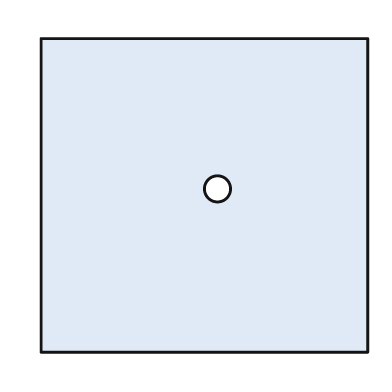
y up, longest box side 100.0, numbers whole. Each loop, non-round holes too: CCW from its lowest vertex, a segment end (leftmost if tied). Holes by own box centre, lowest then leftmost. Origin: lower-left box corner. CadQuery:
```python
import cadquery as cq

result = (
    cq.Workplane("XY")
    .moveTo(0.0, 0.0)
    .lineTo(100.0, 0.0)
    .lineTo(100.0, 96.0)
    .lineTo(0.0, 96.0)
    .close()
    .moveTo(54.0, 50.0)
    .circle(4.0)
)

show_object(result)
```